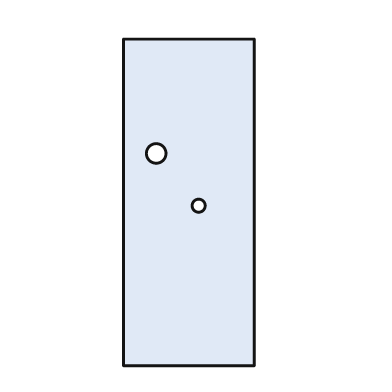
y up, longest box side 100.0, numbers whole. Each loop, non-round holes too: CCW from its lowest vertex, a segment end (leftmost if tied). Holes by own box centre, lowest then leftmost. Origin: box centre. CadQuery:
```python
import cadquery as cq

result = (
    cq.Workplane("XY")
    .moveTo(-20.0, -50.0)
    .lineTo(20.0, -50.0)
    .lineTo(20.0, 50.0)
    .lineTo(-20.0, 50.0)
    .close()
    .moveTo(3.0, -1.0)
    .circle(2.0)
    .moveTo(-10.0, 15.0)
    .circle(3.0)
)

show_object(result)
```